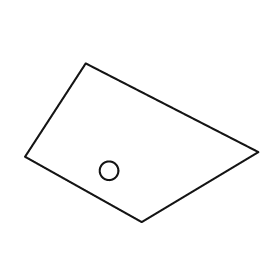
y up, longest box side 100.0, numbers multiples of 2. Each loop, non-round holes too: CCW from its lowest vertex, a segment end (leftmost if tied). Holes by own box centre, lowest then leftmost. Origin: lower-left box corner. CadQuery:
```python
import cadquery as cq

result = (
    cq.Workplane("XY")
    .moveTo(50.0, 0.0)
    .lineTo(100.0, 30.0)
    .lineTo(26.0, 68.0)
    .lineTo(0.0, 28.0)
    .close()
    .moveTo(36.0, 22.0)
    .circle(4.0)
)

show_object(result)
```